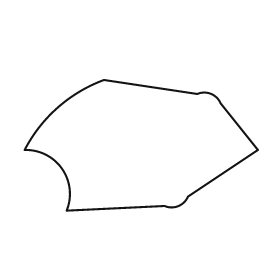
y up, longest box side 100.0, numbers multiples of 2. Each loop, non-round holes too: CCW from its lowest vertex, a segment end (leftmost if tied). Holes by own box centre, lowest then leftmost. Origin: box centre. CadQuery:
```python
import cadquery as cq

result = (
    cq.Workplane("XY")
    .moveTo(-32.0, -28.0)
    .lineTo(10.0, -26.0)
    .threePointArc((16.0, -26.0), (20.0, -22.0))
    .lineTo(50.0, -2.0)
    .lineTo(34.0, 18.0)
    .threePointArc((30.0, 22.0), (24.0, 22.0))
    .lineTo(-16.0, 28.0)
    .threePointArc((-36.0, 16.0), (-50.0, -2.0))
    .threePointArc((-34.0, -10.0), (-32.0, -28.0))
    .close()
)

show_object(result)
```